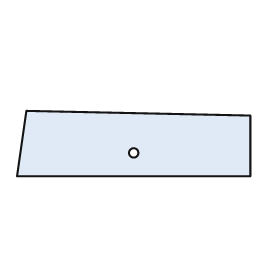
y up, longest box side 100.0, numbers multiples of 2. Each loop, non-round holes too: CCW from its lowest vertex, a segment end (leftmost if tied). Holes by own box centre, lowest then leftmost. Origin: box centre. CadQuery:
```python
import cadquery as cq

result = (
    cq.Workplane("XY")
    .moveTo(-50.0, -14.0)
    .lineTo(50.0, -14.0)
    .lineTo(50.0, 12.0)
    .lineTo(-46.0, 14.0)
    .close()
    .moveTo(0.0, -4.0)
    .circle(2.0)
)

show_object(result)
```